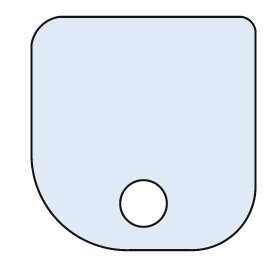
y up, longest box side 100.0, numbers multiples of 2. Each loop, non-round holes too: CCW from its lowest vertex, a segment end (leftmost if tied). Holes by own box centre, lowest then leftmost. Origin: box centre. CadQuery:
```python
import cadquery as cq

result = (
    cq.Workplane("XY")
    .moveTo(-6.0, -50.0)
    .lineTo(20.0, -50.0)
    .threePointArc((40.0, -42.0), (48.0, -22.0))
    .lineTo(48.0, 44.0)
    .threePointArc((46.0, 48.0), (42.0, 50.0))
    .lineTo(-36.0, 50.0)
    .threePointArc((-44.0, 46.0), (-48.0, 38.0))
    .lineTo(-48.0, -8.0)
    .threePointArc((-36.0, -38.0), (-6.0, -50.0))
    .close()
    .moveTo(0.0, -30.0)
    .circle(10.0)
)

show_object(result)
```